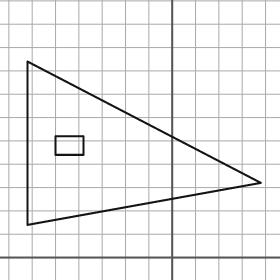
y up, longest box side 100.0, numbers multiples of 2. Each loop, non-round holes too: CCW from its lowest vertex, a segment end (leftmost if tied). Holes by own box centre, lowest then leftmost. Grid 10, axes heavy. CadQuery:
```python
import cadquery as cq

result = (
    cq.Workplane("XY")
    .moveTo(-62.0, 14.0)
    .lineTo(38.0, 32.0)
    .lineTo(-62.0, 84.0)
    .close()
    .moveTo(-50.0, 44.0)
    .lineTo(-38.0, 44.0)
    .lineTo(-38.0, 52.0)
    .lineTo(-50.0, 52.0)
    .close()
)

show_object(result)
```